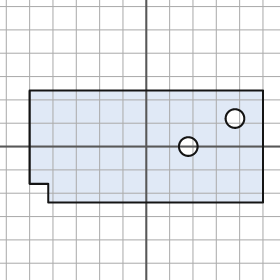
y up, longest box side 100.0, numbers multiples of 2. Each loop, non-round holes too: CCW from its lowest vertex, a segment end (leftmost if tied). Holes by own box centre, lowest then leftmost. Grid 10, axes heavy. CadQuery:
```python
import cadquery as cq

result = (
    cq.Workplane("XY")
    .moveTo(-42.0, -24.0)
    .lineTo(50.0, -24.0)
    .lineTo(50.0, 24.0)
    .lineTo(-50.0, 24.0)
    .lineTo(-50.0, -16.0)
    .lineTo(-42.0, -16.0)
    .close()
    .moveTo(18.0, 0.0)
    .circle(4.0)
    .moveTo(38.0, 12.0)
    .circle(4.0)
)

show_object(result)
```